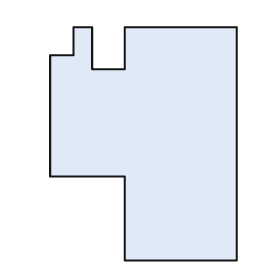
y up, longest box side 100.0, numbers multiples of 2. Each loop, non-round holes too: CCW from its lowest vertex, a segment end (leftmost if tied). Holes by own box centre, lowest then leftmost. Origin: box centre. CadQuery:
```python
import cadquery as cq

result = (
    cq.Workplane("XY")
    .moveTo(-8.0, -50.0)
    .lineTo(40.0, -50.0)
    .lineTo(40.0, 50.0)
    .lineTo(-8.0, 50.0)
    .lineTo(-8.0, 32.0)
    .lineTo(-22.0, 32.0)
    .lineTo(-22.0, 50.0)
    .lineTo(-30.0, 50.0)
    .lineTo(-30.0, 38.0)
    .lineTo(-40.0, 38.0)
    .lineTo(-40.0, -14.0)
    .lineTo(-8.0, -14.0)
    .close()
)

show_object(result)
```